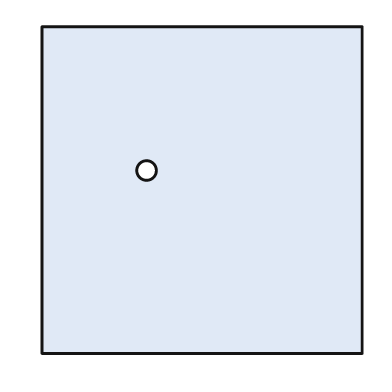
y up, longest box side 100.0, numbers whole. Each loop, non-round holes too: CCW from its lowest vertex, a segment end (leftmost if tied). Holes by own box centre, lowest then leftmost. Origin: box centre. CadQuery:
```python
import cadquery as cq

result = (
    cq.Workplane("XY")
    .moveTo(-49.0, -50.0)
    .lineTo(49.0, -50.0)
    .lineTo(49.0, 50.0)
    .lineTo(-49.0, 50.0)
    .close()
    .moveTo(-17.0, 6.0)
    .circle(3.0)
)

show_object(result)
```